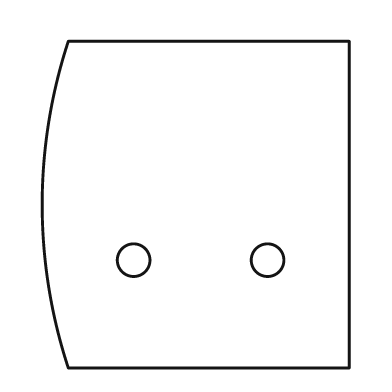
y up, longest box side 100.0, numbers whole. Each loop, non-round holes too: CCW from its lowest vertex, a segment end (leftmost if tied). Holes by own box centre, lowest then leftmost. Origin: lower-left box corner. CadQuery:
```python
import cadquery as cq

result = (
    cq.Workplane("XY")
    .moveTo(8.0, 0.0)
    .lineTo(94.0, 0.0)
    .lineTo(94.0, 100.0)
    .lineTo(8.0, 100.0)
    .threePointArc((0.0, 50.0), (8.0, 0.0))
    .close()
    .moveTo(28.0, 33.0)
    .circle(5.0)
    .moveTo(69.0, 33.0)
    .circle(5.0)
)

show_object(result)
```